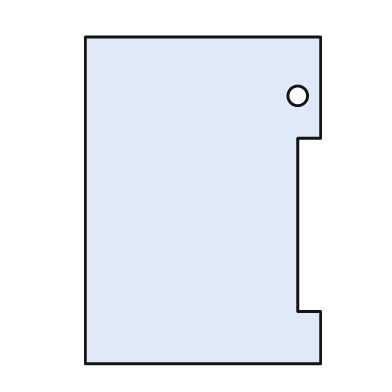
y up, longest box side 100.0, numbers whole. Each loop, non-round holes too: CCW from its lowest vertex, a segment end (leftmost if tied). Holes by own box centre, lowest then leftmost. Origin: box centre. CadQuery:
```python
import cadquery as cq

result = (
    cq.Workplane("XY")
    .moveTo(-36.0, -50.0)
    .lineTo(36.0, -50.0)
    .lineTo(36.0, -34.0)
    .lineTo(29.0, -34.0)
    .lineTo(29.0, 19.0)
    .lineTo(36.0, 19.0)
    .lineTo(36.0, 50.0)
    .lineTo(-36.0, 50.0)
    .close()
    .moveTo(29.0, 32.0)
    .circle(3.0)
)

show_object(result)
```